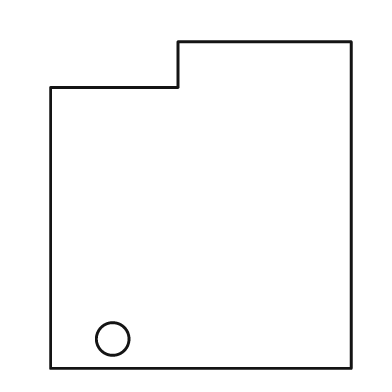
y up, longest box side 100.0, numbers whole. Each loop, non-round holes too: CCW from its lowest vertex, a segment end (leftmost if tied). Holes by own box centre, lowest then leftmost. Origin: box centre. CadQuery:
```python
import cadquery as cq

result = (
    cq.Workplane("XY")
    .moveTo(-46.0, -50.0)
    .lineTo(46.0, -50.0)
    .lineTo(46.0, 50.0)
    .lineTo(-7.0, 50.0)
    .lineTo(-7.0, 36.0)
    .lineTo(-46.0, 36.0)
    .close()
    .moveTo(-27.0, -41.0)
    .circle(5.0)
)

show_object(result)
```